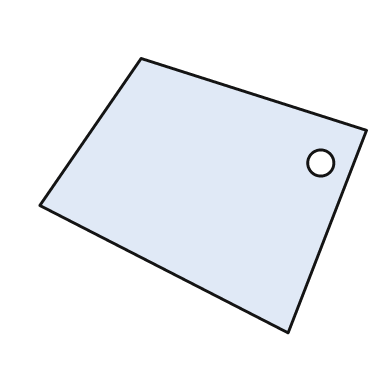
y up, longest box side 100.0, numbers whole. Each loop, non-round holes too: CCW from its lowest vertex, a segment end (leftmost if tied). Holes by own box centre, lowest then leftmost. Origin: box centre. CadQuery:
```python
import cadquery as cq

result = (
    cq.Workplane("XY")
    .moveTo(26.0, -42.0)
    .lineTo(50.0, 20.0)
    .lineTo(-19.0, 42.0)
    .lineTo(-50.0, -3.0)
    .close()
    .moveTo(36.0, 10.0)
    .circle(4.0)
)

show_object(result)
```